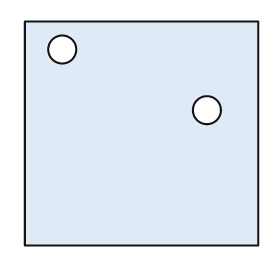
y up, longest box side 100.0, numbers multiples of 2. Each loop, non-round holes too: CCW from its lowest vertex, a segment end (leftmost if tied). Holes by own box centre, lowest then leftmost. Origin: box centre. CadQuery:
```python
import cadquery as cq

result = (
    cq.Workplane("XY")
    .moveTo(-50.0, -48.0)
    .lineTo(50.0, -48.0)
    .lineTo(50.0, 48.0)
    .lineTo(-50.0, 48.0)
    .close()
    .moveTo(28.0, 10.0)
    .circle(6.0)
    .moveTo(-34.0, 36.0)
    .circle(6.0)
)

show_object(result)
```